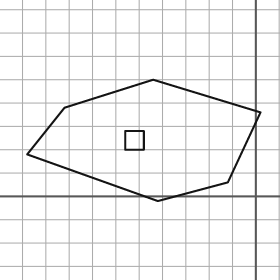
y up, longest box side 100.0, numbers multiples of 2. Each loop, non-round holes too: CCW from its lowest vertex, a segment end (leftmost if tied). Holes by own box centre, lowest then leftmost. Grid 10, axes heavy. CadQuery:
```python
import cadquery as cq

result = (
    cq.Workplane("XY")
    .moveTo(-42.0, -2.0)
    .lineTo(-12.0, 6.0)
    .lineTo(2.0, 36.0)
    .lineTo(-44.0, 50.0)
    .lineTo(-82.0, 38.0)
    .lineTo(-98.0, 18.0)
    .close()
    .moveTo(-56.0, 20.0)
    .lineTo(-48.0, 20.0)
    .lineTo(-48.0, 28.0)
    .lineTo(-56.0, 28.0)
    .close()
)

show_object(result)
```